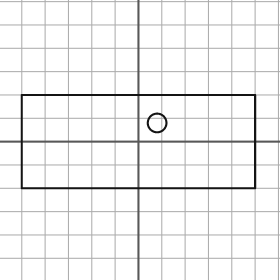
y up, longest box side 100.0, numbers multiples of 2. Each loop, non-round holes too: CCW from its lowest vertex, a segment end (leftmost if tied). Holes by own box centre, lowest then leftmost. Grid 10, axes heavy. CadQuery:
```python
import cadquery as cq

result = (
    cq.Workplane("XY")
    .moveTo(-50.0, -20.0)
    .lineTo(50.0, -20.0)
    .lineTo(50.0, 20.0)
    .lineTo(-50.0, 20.0)
    .close()
    .moveTo(8.0, 8.0)
    .circle(4.0)
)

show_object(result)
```